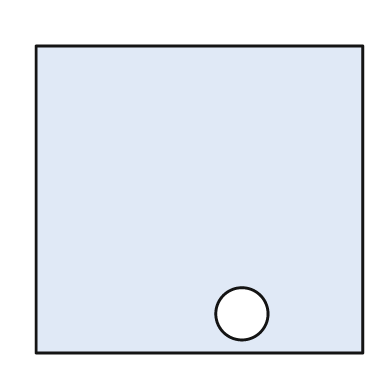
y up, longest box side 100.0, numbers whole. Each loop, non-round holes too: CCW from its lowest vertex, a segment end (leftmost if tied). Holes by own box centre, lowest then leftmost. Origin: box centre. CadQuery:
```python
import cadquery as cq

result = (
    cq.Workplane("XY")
    .moveTo(-50.0, -47.0)
    .lineTo(50.0, -47.0)
    .lineTo(50.0, 47.0)
    .lineTo(-50.0, 47.0)
    .close()
    .moveTo(13.0, -35.0)
    .circle(8.0)
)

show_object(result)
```